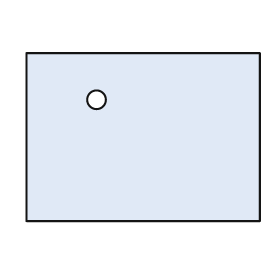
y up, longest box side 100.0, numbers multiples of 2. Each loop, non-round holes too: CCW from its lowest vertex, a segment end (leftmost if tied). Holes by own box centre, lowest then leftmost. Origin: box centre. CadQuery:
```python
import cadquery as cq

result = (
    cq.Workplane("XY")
    .moveTo(-50.0, -36.0)
    .lineTo(50.0, -36.0)
    .lineTo(50.0, 36.0)
    .lineTo(-50.0, 36.0)
    .close()
    .moveTo(-20.0, 16.0)
    .circle(4.0)
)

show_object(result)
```